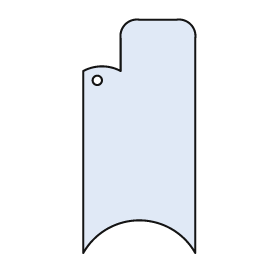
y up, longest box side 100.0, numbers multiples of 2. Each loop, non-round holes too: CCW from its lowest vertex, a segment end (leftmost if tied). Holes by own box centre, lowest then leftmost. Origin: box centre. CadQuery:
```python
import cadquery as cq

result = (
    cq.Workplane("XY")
    .moveTo(-24.0, -50.0)
    .threePointArc((0.0, -36.0), (24.0, -50.0))
    .lineTo(24.0, 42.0)
    .threePointArc((22.0, 48.0), (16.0, 50.0))
    .lineTo(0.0, 50.0)
    .threePointArc((-6.0, 48.0), (-8.0, 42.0))
    .lineTo(-8.0, 28.0)
    .threePointArc((-16.0, 30.0), (-24.0, 28.0))
    .close()
    .moveTo(-18.0, 24.0)
    .circle(2.0)
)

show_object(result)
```